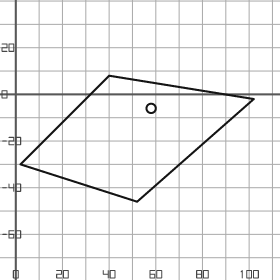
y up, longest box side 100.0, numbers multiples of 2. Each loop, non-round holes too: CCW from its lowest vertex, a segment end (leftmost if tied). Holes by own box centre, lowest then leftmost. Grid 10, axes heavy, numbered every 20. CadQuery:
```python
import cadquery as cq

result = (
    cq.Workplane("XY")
    .moveTo(52.0, -46.0)
    .lineTo(102.0, -2.0)
    .lineTo(40.0, 8.0)
    .lineTo(2.0, -30.0)
    .close()
    .moveTo(58.0, -6.0)
    .circle(2.0)
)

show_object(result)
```